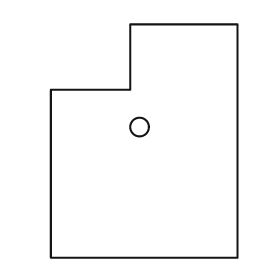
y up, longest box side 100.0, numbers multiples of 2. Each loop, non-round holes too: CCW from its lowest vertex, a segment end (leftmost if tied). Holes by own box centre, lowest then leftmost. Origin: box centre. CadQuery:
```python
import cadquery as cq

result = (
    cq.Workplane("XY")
    .moveTo(-40.0, -50.0)
    .lineTo(40.0, -50.0)
    .lineTo(40.0, 50.0)
    .lineTo(-6.0, 50.0)
    .lineTo(-6.0, 22.0)
    .lineTo(-40.0, 22.0)
    .close()
    .moveTo(-2.0, 6.0)
    .circle(4.0)
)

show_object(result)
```